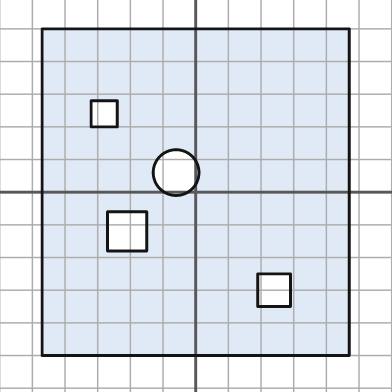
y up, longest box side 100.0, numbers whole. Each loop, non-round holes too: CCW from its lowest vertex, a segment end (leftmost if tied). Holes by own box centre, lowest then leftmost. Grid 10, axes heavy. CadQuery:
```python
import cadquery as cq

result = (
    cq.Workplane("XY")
    .moveTo(-47.0, -50.0)
    .lineTo(47.0, -50.0)
    .lineTo(47.0, 50.0)
    .lineTo(-47.0, 50.0)
    .close()
    .moveTo(19.0, -35.0)
    .lineTo(29.0, -35.0)
    .lineTo(29.0, -25.0)
    .lineTo(19.0, -25.0)
    .close()
    .moveTo(-27.0, -18.0)
    .lineTo(-15.0, -18.0)
    .lineTo(-15.0, -6.0)
    .lineTo(-27.0, -6.0)
    .close()
    .moveTo(-6.0, 6.0)
    .circle(7.0)
    .moveTo(-32.0, 20.0)
    .lineTo(-24.0, 20.0)
    .lineTo(-24.0, 28.0)
    .lineTo(-32.0, 28.0)
    .close()
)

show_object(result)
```